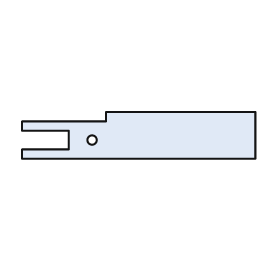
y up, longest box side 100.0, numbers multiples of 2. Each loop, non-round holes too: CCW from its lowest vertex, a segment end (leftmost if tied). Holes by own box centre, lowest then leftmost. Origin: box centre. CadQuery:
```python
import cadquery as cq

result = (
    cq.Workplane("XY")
    .moveTo(-50.0, -10.0)
    .lineTo(50.0, -10.0)
    .lineTo(50.0, 10.0)
    .lineTo(-14.0, 10.0)
    .lineTo(-14.0, 6.0)
    .lineTo(-50.0, 6.0)
    .lineTo(-50.0, 2.0)
    .lineTo(-30.0, 2.0)
    .lineTo(-30.0, -6.0)
    .lineTo(-50.0, -6.0)
    .close()
    .moveTo(-20.0, -2.0)
    .circle(2.0)
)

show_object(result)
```